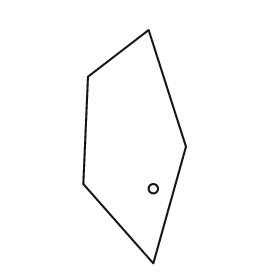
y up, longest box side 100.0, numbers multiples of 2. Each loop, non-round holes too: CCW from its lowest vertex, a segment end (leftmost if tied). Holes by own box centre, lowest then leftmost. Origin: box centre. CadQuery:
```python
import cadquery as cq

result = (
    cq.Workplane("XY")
    .moveTo(8.0, -50.0)
    .lineTo(22.0, 0.0)
    .lineTo(6.0, 50.0)
    .lineTo(-20.0, 30.0)
    .lineTo(-22.0, -16.0)
    .close()
    .moveTo(8.0, -18.0)
    .circle(2.0)
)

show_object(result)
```